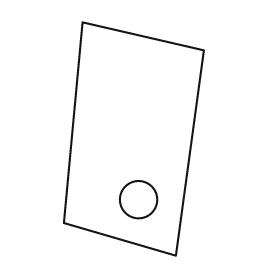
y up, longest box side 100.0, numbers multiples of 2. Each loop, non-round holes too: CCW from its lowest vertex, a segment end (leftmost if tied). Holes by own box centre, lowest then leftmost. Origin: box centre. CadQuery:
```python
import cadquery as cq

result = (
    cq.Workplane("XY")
    .moveTo(18.0, -50.0)
    .lineTo(30.0, 38.0)
    .lineTo(-22.0, 50.0)
    .lineTo(-30.0, -36.0)
    .close()
    .moveTo(2.0, -26.0)
    .circle(8.0)
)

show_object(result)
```